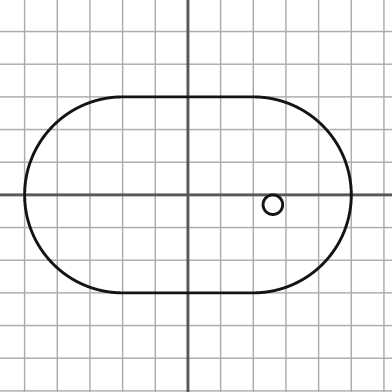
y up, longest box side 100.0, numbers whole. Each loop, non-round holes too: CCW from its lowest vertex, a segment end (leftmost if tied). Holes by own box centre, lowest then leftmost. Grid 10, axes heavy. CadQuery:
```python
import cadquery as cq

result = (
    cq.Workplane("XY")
    .moveTo(-20.0, -30.0)
    .lineTo(20.0, -30.0)
    .threePointArc((50.0, 0.0), (20.0, 30.0))
    .lineTo(-20.0, 30.0)
    .threePointArc((-50.0, 0.0), (-20.0, -30.0))
    .close()
    .moveTo(26.0, -3.0)
    .circle(3.0)
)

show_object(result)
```